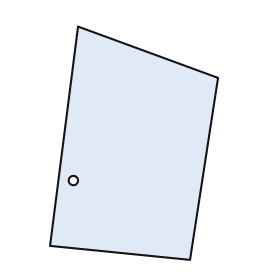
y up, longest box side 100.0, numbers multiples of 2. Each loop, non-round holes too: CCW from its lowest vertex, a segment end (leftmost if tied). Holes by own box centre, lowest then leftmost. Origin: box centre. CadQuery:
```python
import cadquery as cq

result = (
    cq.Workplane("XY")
    .moveTo(24.0, -50.0)
    .lineTo(36.0, 28.0)
    .lineTo(-24.0, 50.0)
    .lineTo(-36.0, -44.0)
    .close()
    .moveTo(-26.0, -16.0)
    .circle(2.0)
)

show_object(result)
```